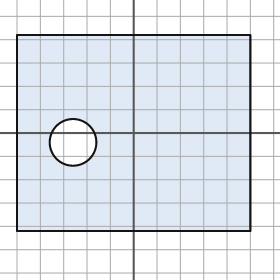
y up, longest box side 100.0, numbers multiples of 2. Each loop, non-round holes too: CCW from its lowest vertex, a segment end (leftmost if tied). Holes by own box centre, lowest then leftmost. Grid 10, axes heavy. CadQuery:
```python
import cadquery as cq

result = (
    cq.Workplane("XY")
    .moveTo(-50.0, -42.0)
    .lineTo(50.0, -42.0)
    .lineTo(50.0, 42.0)
    .lineTo(-50.0, 42.0)
    .close()
    .moveTo(-26.0, -4.0)
    .circle(10.0)
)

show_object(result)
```